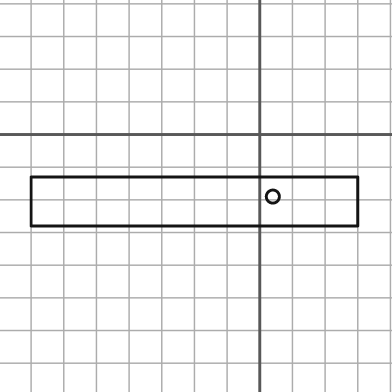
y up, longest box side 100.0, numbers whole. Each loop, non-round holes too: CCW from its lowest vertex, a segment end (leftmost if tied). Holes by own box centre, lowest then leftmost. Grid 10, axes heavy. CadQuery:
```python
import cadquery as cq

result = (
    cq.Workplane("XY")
    .moveTo(-70.0, -28.0)
    .lineTo(30.0, -28.0)
    .lineTo(30.0, -13.0)
    .lineTo(-70.0, -13.0)
    .close()
    .moveTo(4.0, -19.0)
    .circle(2.0)
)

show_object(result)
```